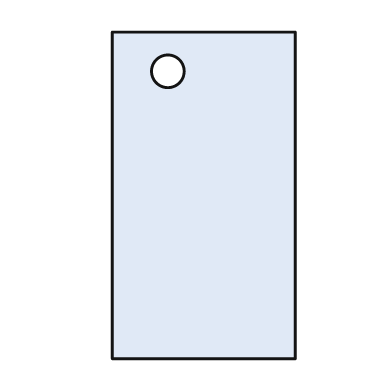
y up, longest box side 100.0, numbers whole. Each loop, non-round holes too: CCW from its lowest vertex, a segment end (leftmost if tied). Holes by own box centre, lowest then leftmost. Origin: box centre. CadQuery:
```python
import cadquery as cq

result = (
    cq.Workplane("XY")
    .moveTo(-28.0, -50.0)
    .lineTo(28.0, -50.0)
    .lineTo(28.0, 50.0)
    .lineTo(-28.0, 50.0)
    .close()
    .moveTo(-11.0, 38.0)
    .circle(5.0)
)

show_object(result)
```